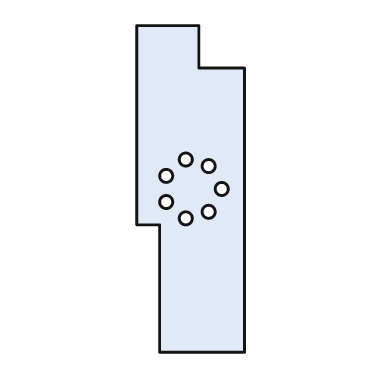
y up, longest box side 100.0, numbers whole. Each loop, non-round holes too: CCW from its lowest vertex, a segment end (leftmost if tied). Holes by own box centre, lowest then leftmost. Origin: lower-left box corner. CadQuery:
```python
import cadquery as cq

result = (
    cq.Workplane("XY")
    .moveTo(7.0, 0.0)
    .lineTo(33.0, 0.0)
    .lineTo(33.0, 87.0)
    .lineTo(19.0, 87.0)
    .lineTo(19.0, 100.0)
    .lineTo(0.0, 100.0)
    .lineTo(0.0, 39.0)
    .lineTo(7.0, 39.0)
    .close()
    .moveTo(15.0, 41.0)
    .circle(2.0)
    .moveTo(22.0, 43.0)
    .circle(2.0)
    .moveTo(9.0, 46.0)
    .circle(2.0)
    .moveTo(26.0, 50.0)
    .circle(2.0)
    .moveTo(9.0, 54.0)
    .circle(2.0)
    .moveTo(22.0, 57.0)
    .circle(2.0)
    .moveTo(15.0, 59.0)
    .circle(2.0)
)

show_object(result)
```